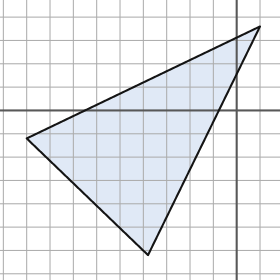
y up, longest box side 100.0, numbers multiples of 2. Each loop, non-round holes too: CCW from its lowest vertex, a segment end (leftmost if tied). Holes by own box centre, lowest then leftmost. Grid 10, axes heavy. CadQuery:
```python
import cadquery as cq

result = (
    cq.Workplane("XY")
    .moveTo(-38.0, -62.0)
    .lineTo(10.0, 36.0)
    .lineTo(-90.0, -12.0)
    .close()
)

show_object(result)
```